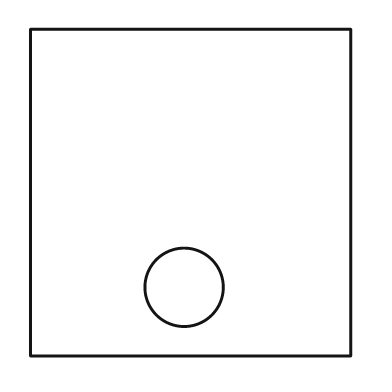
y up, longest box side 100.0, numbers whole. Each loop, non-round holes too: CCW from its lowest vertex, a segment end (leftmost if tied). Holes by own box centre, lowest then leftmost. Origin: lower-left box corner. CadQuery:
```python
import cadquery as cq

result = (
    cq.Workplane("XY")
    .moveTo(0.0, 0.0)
    .lineTo(98.0, 0.0)
    .lineTo(98.0, 100.0)
    .lineTo(0.0, 100.0)
    .close()
    .moveTo(47.0, 21.0)
    .circle(12.0)
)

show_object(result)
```